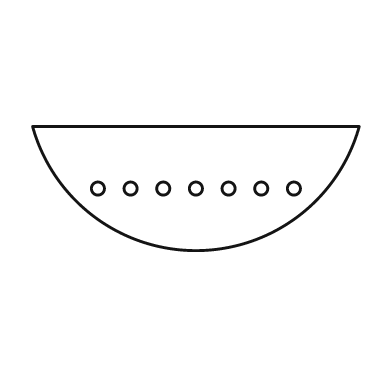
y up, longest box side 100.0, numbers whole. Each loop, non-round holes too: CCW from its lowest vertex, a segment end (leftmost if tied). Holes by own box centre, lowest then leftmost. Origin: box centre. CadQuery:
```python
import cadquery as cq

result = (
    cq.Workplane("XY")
    .moveTo(-50.0, 19.0)
    .threePointArc((0.0, -19.0), (50.0, 19.0))
    .close()
    .moveTo(-30.0, 0.0)
    .circle(2.0)
    .moveTo(-20.0, 0.0)
    .circle(2.0)
    .moveTo(-10.0, 0.0)
    .circle(2.0)
    .moveTo(0.0, 0.0)
    .circle(2.0)
    .moveTo(10.0, 0.0)
    .circle(2.0)
    .moveTo(20.0, 0.0)
    .circle(2.0)
    .moveTo(30.0, 0.0)
    .circle(2.0)
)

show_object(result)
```